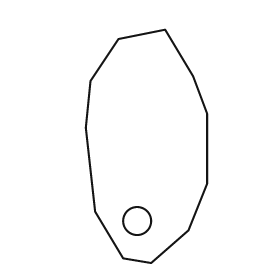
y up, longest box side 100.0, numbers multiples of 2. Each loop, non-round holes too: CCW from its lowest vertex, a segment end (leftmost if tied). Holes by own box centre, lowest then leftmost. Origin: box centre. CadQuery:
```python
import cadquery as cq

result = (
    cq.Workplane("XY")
    .moveTo(2.0, -50.0)
    .lineTo(18.0, -36.0)
    .lineTo(26.0, -16.0)
    .lineTo(26.0, 14.0)
    .lineTo(20.0, 30.0)
    .lineTo(8.0, 50.0)
    .lineTo(-12.0, 46.0)
    .lineTo(-24.0, 28.0)
    .lineTo(-26.0, 8.0)
    .lineTo(-22.0, -28.0)
    .lineTo(-10.0, -48.0)
    .close()
    .moveTo(-4.0, -32.0)
    .circle(6.0)
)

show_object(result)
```